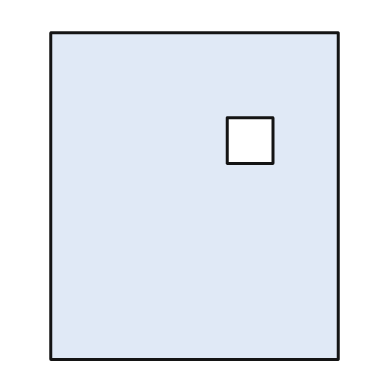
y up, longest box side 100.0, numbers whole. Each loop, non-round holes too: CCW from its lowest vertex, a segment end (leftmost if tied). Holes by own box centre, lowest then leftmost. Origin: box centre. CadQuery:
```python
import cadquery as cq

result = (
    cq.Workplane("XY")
    .moveTo(-44.0, -50.0)
    .lineTo(44.0, -50.0)
    .lineTo(44.0, 50.0)
    .lineTo(-44.0, 50.0)
    .close()
    .moveTo(10.0, 10.0)
    .lineTo(24.0, 10.0)
    .lineTo(24.0, 24.0)
    .lineTo(10.0, 24.0)
    .close()
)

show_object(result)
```